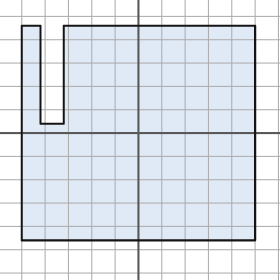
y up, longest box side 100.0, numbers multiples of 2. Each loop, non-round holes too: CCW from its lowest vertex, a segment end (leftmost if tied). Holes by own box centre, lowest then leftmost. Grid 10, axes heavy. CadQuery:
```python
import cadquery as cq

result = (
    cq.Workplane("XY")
    .moveTo(-50.0, -46.0)
    .lineTo(50.0, -46.0)
    .lineTo(50.0, 46.0)
    .lineTo(-32.0, 46.0)
    .lineTo(-32.0, 4.0)
    .lineTo(-42.0, 4.0)
    .lineTo(-42.0, 46.0)
    .lineTo(-50.0, 46.0)
    .close()
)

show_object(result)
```